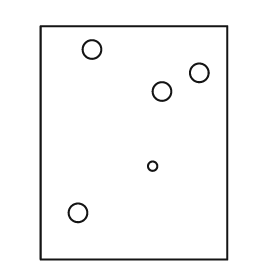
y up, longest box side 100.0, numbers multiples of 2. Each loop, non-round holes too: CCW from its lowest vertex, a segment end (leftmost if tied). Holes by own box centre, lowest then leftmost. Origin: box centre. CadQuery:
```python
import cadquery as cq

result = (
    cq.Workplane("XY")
    .moveTo(-40.0, -50.0)
    .lineTo(40.0, -50.0)
    .lineTo(40.0, 50.0)
    .lineTo(-40.0, 50.0)
    .close()
    .moveTo(-24.0, -30.0)
    .circle(4.0)
    .moveTo(8.0, -10.0)
    .circle(2.0)
    .moveTo(12.0, 22.0)
    .circle(4.0)
    .moveTo(28.0, 30.0)
    .circle(4.0)
    .moveTo(-18.0, 40.0)
    .circle(4.0)
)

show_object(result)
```